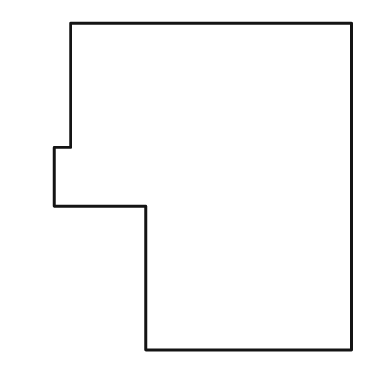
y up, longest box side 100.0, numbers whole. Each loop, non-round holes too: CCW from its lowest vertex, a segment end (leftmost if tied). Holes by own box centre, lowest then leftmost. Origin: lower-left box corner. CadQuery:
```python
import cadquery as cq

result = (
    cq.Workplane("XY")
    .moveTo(28.0, 0.0)
    .lineTo(91.0, 0.0)
    .lineTo(91.0, 100.0)
    .lineTo(5.0, 100.0)
    .lineTo(5.0, 62.0)
    .lineTo(0.0, 62.0)
    .lineTo(0.0, 44.0)
    .lineTo(28.0, 44.0)
    .close()
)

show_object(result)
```